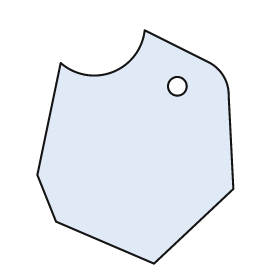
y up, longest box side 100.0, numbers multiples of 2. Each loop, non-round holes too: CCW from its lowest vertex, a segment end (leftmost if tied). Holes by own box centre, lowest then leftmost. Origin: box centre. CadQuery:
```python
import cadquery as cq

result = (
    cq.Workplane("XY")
    .moveTo(8.0, -50.0)
    .lineTo(42.0, -18.0)
    .lineTo(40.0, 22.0)
    .threePointArc((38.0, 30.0), (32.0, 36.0))
    .lineTo(4.0, 50.0)
    .threePointArc((-10.0, 32.0), (-32.0, 36.0))
    .lineTo(-42.0, -12.0)
    .lineTo(-34.0, -32.0)
    .close()
    .moveTo(18.0, 26.0)
    .circle(4.0)
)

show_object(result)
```